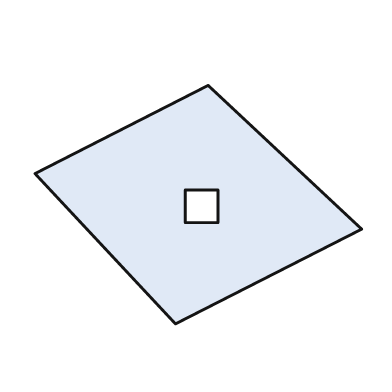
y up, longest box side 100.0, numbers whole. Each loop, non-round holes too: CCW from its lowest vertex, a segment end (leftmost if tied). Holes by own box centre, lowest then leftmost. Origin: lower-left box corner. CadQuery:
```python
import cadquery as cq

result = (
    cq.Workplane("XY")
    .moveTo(43.0, 0.0)
    .lineTo(100.0, 29.0)
    .lineTo(53.0, 73.0)
    .lineTo(0.0, 46.0)
    .close()
    .moveTo(46.0, 31.0)
    .lineTo(56.0, 31.0)
    .lineTo(56.0, 41.0)
    .lineTo(46.0, 41.0)
    .close()
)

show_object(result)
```